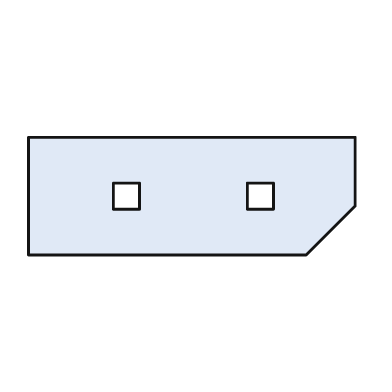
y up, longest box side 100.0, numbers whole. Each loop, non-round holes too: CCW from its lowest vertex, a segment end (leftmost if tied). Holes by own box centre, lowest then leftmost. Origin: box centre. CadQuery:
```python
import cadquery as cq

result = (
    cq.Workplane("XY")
    .moveTo(-50.0, -18.0)
    .lineTo(35.0, -18.0)
    .lineTo(50.0, -3.0)
    .lineTo(50.0, 18.0)
    .lineTo(-50.0, 18.0)
    .close()
    .moveTo(-24.0, -4.0)
    .lineTo(-16.0, -4.0)
    .lineTo(-16.0, 4.0)
    .lineTo(-24.0, 4.0)
    .close()
    .moveTo(17.0, -4.0)
    .lineTo(25.0, -4.0)
    .lineTo(25.0, 4.0)
    .lineTo(17.0, 4.0)
    .close()
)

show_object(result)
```